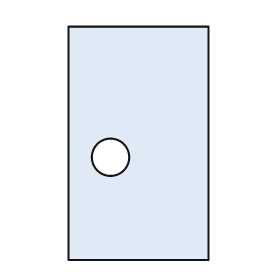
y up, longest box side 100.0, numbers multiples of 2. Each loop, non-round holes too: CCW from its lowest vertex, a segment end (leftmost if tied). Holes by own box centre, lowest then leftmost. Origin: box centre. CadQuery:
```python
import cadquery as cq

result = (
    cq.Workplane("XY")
    .moveTo(-30.0, -50.0)
    .lineTo(30.0, -50.0)
    .lineTo(30.0, 50.0)
    .lineTo(-30.0, 50.0)
    .close()
    .moveTo(-12.0, -6.0)
    .circle(8.0)
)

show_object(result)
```